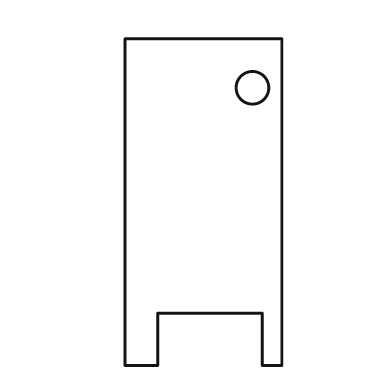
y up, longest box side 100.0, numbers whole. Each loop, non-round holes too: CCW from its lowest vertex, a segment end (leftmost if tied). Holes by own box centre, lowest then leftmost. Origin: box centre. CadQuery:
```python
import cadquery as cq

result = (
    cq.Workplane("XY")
    .moveTo(-24.0, -50.0)
    .lineTo(-14.0, -50.0)
    .lineTo(-14.0, -34.0)
    .lineTo(18.0, -34.0)
    .lineTo(18.0, -50.0)
    .lineTo(24.0, -50.0)
    .lineTo(24.0, 50.0)
    .lineTo(-24.0, 50.0)
    .close()
    .moveTo(15.0, 35.0)
    .circle(5.0)
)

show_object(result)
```